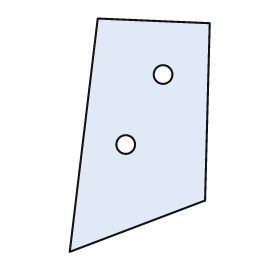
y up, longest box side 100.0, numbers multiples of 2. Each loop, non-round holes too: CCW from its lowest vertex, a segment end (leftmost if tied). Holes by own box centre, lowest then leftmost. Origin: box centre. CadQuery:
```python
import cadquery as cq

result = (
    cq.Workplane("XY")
    .moveTo(-30.0, -50.0)
    .lineTo(28.0, -28.0)
    .lineTo(30.0, 48.0)
    .lineTo(-18.0, 50.0)
    .close()
    .moveTo(-6.0, -4.0)
    .circle(4.0)
    .moveTo(10.0, 26.0)
    .circle(4.0)
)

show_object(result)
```